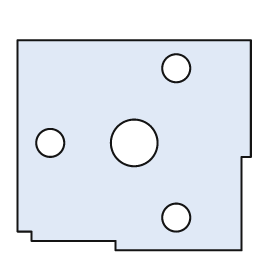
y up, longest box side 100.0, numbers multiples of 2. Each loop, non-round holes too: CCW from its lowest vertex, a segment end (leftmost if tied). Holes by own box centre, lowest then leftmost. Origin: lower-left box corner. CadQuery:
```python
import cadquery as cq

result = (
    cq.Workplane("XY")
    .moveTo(42.0, 0.0)
    .lineTo(96.0, 0.0)
    .lineTo(96.0, 40.0)
    .lineTo(100.0, 40.0)
    .lineTo(100.0, 90.0)
    .lineTo(0.0, 90.0)
    .lineTo(0.0, 8.0)
    .lineTo(6.0, 8.0)
    .lineTo(6.0, 4.0)
    .lineTo(42.0, 4.0)
    .close()
    .moveTo(68.0, 14.0)
    .circle(6.0)
    .moveTo(14.0, 46.0)
    .circle(6.0)
    .moveTo(50.0, 46.0)
    .circle(10.0)
    .moveTo(68.0, 78.0)
    .circle(6.0)
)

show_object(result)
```